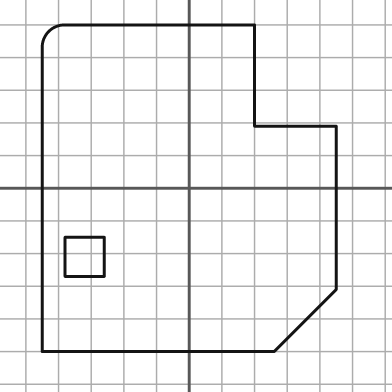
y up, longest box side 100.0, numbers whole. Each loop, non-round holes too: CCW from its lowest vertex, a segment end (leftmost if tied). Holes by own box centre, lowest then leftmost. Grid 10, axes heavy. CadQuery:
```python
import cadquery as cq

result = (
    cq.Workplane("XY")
    .moveTo(-45.0, -50.0)
    .lineTo(26.0, -50.0)
    .lineTo(45.0, -31.0)
    .lineTo(45.0, 19.0)
    .lineTo(20.0, 19.0)
    .lineTo(20.0, 50.0)
    .lineTo(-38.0, 50.0)
    .threePointArc((-43.0, 48.0), (-45.0, 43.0))
    .close()
    .moveTo(-38.0, -27.0)
    .lineTo(-26.0, -27.0)
    .lineTo(-26.0, -15.0)
    .lineTo(-38.0, -15.0)
    .close()
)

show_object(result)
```